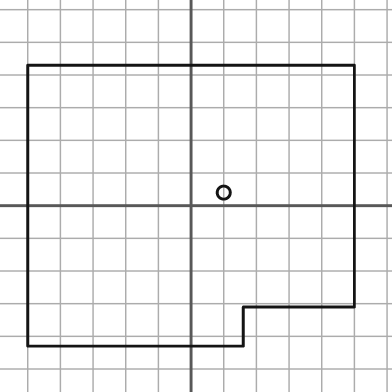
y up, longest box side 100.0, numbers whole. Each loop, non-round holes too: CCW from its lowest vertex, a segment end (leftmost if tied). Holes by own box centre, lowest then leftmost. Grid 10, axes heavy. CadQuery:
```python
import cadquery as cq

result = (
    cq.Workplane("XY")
    .moveTo(-50.0, -43.0)
    .lineTo(16.0, -43.0)
    .lineTo(16.0, -31.0)
    .lineTo(50.0, -31.0)
    .lineTo(50.0, 43.0)
    .lineTo(-50.0, 43.0)
    .close()
    .moveTo(10.0, 4.0)
    .circle(2.0)
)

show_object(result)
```